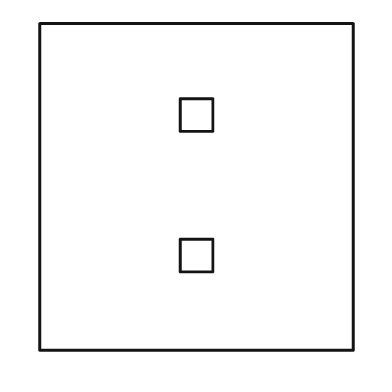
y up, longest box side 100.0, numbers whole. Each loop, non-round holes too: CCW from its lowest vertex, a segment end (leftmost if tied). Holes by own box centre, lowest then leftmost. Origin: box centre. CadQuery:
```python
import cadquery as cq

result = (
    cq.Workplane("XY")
    .moveTo(-48.0, -50.0)
    .lineTo(48.0, -50.0)
    .lineTo(48.0, 50.0)
    .lineTo(-48.0, 50.0)
    .close()
    .moveTo(-5.0, -26.0)
    .lineTo(5.0, -26.0)
    .lineTo(5.0, -16.0)
    .lineTo(-5.0, -16.0)
    .close()
    .moveTo(-5.0, 17.0)
    .lineTo(5.0, 17.0)
    .lineTo(5.0, 27.0)
    .lineTo(-5.0, 27.0)
    .close()
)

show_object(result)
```